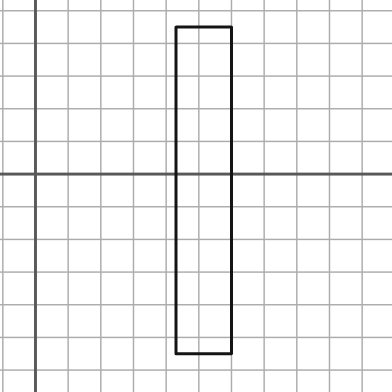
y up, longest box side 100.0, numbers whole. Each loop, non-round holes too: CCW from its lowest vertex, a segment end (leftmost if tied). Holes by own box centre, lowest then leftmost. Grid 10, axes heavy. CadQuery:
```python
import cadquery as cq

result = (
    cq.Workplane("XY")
    .moveTo(43.0, -55.0)
    .lineTo(60.0, -55.0)
    .lineTo(60.0, 45.0)
    .lineTo(43.0, 45.0)
    .close()
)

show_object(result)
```